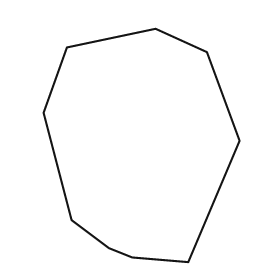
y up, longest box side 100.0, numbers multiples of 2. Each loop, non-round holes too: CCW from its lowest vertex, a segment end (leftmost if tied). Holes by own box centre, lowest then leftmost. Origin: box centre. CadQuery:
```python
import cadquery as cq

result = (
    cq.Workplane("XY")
    .moveTo(20.0, -50.0)
    .lineTo(42.0, 2.0)
    .lineTo(28.0, 40.0)
    .lineTo(6.0, 50.0)
    .lineTo(-32.0, 42.0)
    .lineTo(-42.0, 14.0)
    .lineTo(-30.0, -32.0)
    .lineTo(-14.0, -44.0)
    .lineTo(-4.0, -48.0)
    .close()
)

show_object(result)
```